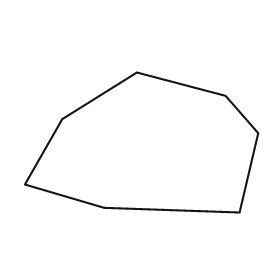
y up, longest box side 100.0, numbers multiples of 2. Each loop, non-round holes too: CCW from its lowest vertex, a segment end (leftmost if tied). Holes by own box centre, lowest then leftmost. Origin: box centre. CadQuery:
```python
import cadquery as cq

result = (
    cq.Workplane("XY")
    .moveTo(42.0, -30.0)
    .lineTo(50.0, 4.0)
    .lineTo(36.0, 20.0)
    .lineTo(-2.0, 30.0)
    .lineTo(-34.0, 10.0)
    .lineTo(-50.0, -18.0)
    .lineTo(-16.0, -28.0)
    .close()
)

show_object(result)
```